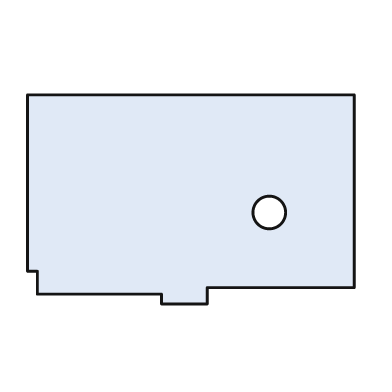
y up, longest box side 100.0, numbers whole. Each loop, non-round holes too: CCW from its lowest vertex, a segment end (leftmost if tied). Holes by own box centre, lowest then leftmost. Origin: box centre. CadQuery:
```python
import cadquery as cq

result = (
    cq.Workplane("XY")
    .moveTo(-9.0, -32.0)
    .lineTo(5.0, -32.0)
    .lineTo(5.0, -27.0)
    .lineTo(50.0, -27.0)
    .lineTo(50.0, 32.0)
    .lineTo(-50.0, 32.0)
    .lineTo(-50.0, -22.0)
    .lineTo(-47.0, -22.0)
    .lineTo(-47.0, -29.0)
    .lineTo(-9.0, -29.0)
    .close()
    .moveTo(24.0, -4.0)
    .circle(5.0)
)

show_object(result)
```